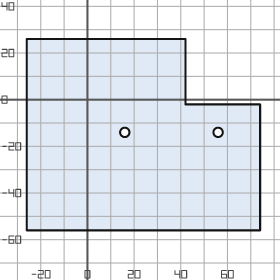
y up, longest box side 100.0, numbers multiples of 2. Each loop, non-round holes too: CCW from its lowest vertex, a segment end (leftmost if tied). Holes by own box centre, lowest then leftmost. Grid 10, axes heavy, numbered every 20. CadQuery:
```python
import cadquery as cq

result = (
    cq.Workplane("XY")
    .moveTo(-26.0, -56.0)
    .lineTo(74.0, -56.0)
    .lineTo(74.0, -2.0)
    .lineTo(42.0, -2.0)
    .lineTo(42.0, 26.0)
    .lineTo(-26.0, 26.0)
    .close()
    .moveTo(16.0, -14.0)
    .circle(2.0)
    .moveTo(56.0, -14.0)
    .circle(2.0)
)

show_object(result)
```